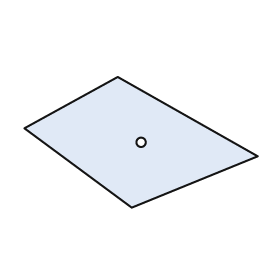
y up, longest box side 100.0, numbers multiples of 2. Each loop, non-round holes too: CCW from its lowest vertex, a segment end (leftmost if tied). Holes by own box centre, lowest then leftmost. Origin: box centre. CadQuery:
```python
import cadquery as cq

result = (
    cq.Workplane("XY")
    .moveTo(-4.0, -28.0)
    .lineTo(50.0, -6.0)
    .lineTo(-10.0, 28.0)
    .lineTo(-50.0, 6.0)
    .close()
    .moveTo(0.0, 0.0)
    .circle(2.0)
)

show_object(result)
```